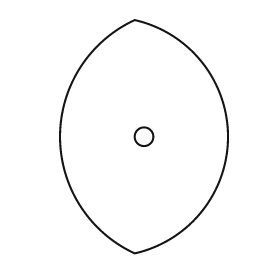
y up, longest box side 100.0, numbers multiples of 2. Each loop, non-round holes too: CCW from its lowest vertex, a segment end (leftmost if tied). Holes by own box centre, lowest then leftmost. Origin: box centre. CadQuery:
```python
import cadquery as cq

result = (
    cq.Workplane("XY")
    .moveTo(-4.0, -50.0)
    .threePointArc((36.0, 0.0), (-4.0, 50.0))
    .threePointArc((-36.0, 0.0), (-4.0, -50.0))
    .close()
    .moveTo(0.0, 0.0)
    .circle(4.0)
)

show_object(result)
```